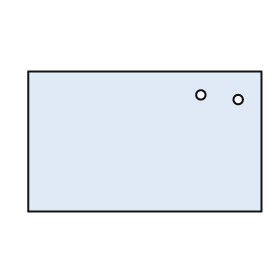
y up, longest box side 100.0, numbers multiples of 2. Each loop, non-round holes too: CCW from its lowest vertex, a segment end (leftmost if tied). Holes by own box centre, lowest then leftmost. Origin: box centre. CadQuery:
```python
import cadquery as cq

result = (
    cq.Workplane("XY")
    .moveTo(-50.0, -30.0)
    .lineTo(50.0, -30.0)
    .lineTo(50.0, 30.0)
    .lineTo(-50.0, 30.0)
    .close()
    .moveTo(40.0, 18.0)
    .circle(2.0)
    .moveTo(24.0, 20.0)
    .circle(2.0)
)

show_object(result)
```